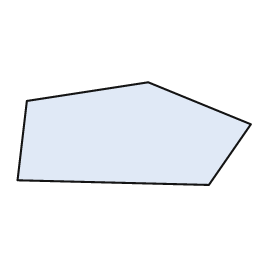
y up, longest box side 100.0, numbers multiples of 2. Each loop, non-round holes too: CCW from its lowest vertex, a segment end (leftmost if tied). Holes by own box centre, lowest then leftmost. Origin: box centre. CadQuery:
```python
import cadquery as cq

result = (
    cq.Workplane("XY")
    .moveTo(32.0, -22.0)
    .lineTo(50.0, 4.0)
    .lineTo(6.0, 22.0)
    .lineTo(-46.0, 14.0)
    .lineTo(-50.0, -20.0)
    .close()
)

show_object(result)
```